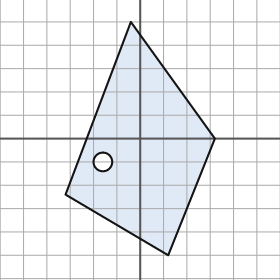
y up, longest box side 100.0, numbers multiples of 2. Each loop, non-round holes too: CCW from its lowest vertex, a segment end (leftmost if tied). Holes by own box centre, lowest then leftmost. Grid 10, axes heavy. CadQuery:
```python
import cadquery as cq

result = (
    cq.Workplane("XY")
    .moveTo(12.0, -50.0)
    .lineTo(32.0, 0.0)
    .lineTo(-4.0, 50.0)
    .lineTo(-32.0, -24.0)
    .close()
    .moveTo(-16.0, -10.0)
    .circle(4.0)
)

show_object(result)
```